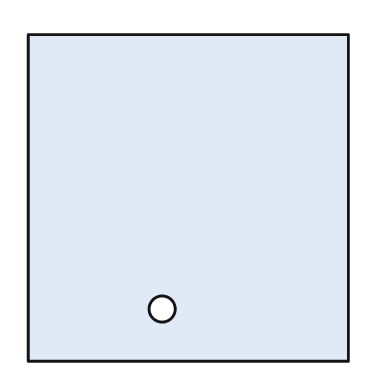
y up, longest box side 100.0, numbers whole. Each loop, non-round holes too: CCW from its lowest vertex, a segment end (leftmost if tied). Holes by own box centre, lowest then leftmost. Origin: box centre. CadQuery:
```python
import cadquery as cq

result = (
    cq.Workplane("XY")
    .moveTo(-49.0, -50.0)
    .lineTo(49.0, -50.0)
    .lineTo(49.0, 50.0)
    .lineTo(-49.0, 50.0)
    .close()
    .moveTo(-8.0, -34.0)
    .circle(4.0)
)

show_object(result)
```